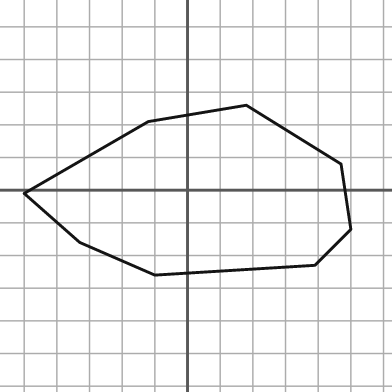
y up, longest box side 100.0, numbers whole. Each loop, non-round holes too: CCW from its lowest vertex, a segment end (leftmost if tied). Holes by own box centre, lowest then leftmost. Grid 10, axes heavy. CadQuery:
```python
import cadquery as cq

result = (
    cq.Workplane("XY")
    .moveTo(-10.0, -26.0)
    .lineTo(39.0, -23.0)
    .lineTo(50.0, -12.0)
    .lineTo(47.0, 8.0)
    .lineTo(18.0, 26.0)
    .lineTo(-12.0, 21.0)
    .lineTo(-50.0, -1.0)
    .lineTo(-33.0, -16.0)
    .close()
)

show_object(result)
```